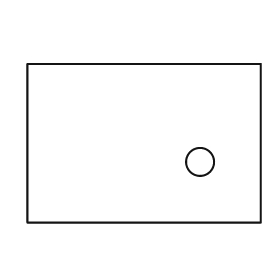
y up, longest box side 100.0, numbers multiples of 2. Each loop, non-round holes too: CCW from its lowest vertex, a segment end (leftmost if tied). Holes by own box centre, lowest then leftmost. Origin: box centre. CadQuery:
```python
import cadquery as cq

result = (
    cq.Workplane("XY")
    .moveTo(-50.0, -34.0)
    .lineTo(50.0, -34.0)
    .lineTo(50.0, 34.0)
    .lineTo(-50.0, 34.0)
    .close()
    .moveTo(24.0, -8.0)
    .circle(6.0)
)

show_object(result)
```